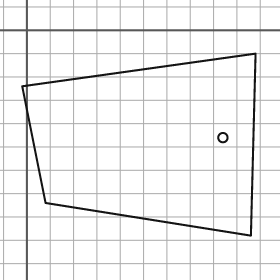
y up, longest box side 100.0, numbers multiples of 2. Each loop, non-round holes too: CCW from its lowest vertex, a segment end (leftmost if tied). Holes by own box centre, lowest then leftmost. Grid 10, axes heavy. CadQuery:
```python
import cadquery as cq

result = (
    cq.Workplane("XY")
    .moveTo(96.0, -88.0)
    .lineTo(98.0, -10.0)
    .lineTo(-2.0, -24.0)
    .lineTo(8.0, -74.0)
    .close()
    .moveTo(84.0, -46.0)
    .circle(2.0)
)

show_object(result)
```